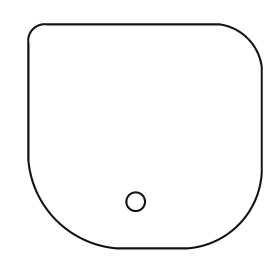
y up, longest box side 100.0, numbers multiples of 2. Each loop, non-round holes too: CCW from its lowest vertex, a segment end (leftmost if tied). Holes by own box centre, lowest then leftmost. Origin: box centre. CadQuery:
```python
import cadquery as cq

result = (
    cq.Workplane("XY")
    .moveTo(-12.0, -48.0)
    .lineTo(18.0, -48.0)
    .threePointArc((40.0, -38.0), (50.0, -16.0))
    .lineTo(50.0, 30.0)
    .threePointArc((44.0, 42.0), (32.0, 48.0))
    .lineTo(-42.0, 48.0)
    .threePointArc((-48.0, 46.0), (-50.0, 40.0))
    .lineTo(-50.0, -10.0)
    .threePointArc((-38.0, -36.0), (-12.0, -48.0))
    .close()
    .moveTo(-4.0, -28.0)
    .circle(4.0)
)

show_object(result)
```